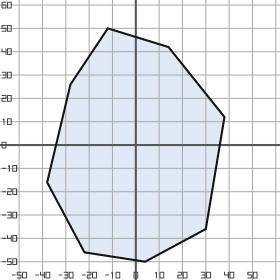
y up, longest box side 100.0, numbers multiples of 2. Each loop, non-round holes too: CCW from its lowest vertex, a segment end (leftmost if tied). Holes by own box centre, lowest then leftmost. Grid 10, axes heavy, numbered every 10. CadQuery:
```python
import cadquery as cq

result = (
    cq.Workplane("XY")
    .moveTo(4.0, -50.0)
    .lineTo(30.0, -36.0)
    .lineTo(38.0, 12.0)
    .lineTo(14.0, 42.0)
    .lineTo(-12.0, 50.0)
    .lineTo(-28.0, 26.0)
    .lineTo(-38.0, -16.0)
    .lineTo(-22.0, -46.0)
    .close()
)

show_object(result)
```